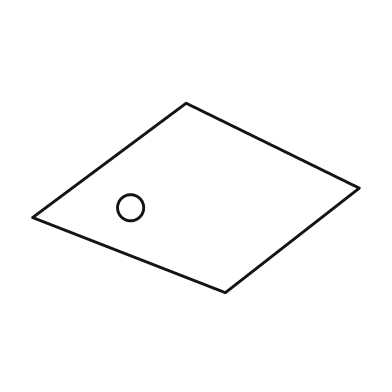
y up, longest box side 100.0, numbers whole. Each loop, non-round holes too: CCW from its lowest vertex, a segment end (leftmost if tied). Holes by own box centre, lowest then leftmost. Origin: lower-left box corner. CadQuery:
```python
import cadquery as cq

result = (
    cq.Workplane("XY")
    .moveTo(59.0, 0.0)
    .lineTo(100.0, 32.0)
    .lineTo(47.0, 58.0)
    .lineTo(0.0, 23.0)
    .close()
    .moveTo(30.0, 26.0)
    .circle(4.0)
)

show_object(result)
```